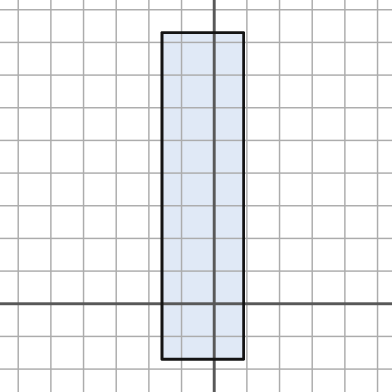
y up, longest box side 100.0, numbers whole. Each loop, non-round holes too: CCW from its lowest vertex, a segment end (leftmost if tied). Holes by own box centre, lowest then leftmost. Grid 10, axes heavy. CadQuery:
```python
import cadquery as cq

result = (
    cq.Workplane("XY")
    .moveTo(-16.0, -17.0)
    .lineTo(9.0, -17.0)
    .lineTo(9.0, 83.0)
    .lineTo(-16.0, 83.0)
    .close()
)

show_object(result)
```